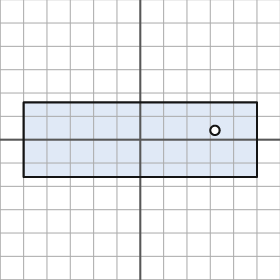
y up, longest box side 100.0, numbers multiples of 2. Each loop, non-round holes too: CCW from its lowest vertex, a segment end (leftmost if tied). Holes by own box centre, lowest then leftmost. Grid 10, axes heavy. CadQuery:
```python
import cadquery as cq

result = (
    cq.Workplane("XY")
    .moveTo(-50.0, -16.0)
    .lineTo(50.0, -16.0)
    .lineTo(50.0, 16.0)
    .lineTo(-50.0, 16.0)
    .close()
    .moveTo(32.0, 4.0)
    .circle(2.0)
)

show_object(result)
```